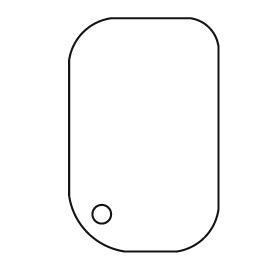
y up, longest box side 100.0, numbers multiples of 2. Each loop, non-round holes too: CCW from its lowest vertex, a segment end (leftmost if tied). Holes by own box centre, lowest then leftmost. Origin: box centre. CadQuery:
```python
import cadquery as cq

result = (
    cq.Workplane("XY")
    .moveTo(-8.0, -50.0)
    .lineTo(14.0, -50.0)
    .threePointArc((26.0, -44.0), (32.0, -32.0))
    .lineTo(32.0, 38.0)
    .threePointArc((28.0, 46.0), (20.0, 50.0))
    .lineTo(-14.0, 50.0)
    .threePointArc((-26.0, 44.0), (-32.0, 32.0))
    .lineTo(-32.0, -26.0)
    .threePointArc((-24.0, -42.0), (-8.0, -50.0))
    .close()
    .moveTo(-18.0, -34.0)
    .circle(4.0)
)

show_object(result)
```